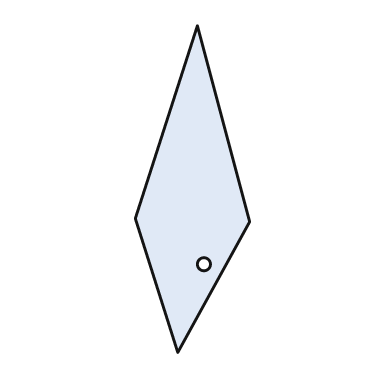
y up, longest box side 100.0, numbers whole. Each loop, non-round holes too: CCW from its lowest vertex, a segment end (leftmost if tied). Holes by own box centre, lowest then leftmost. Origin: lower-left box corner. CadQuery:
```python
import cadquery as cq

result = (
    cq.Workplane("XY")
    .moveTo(13.0, 0.0)
    .lineTo(35.0, 40.0)
    .lineTo(19.0, 100.0)
    .lineTo(0.0, 41.0)
    .close()
    .moveTo(21.0, 27.0)
    .circle(2.0)
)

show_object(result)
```